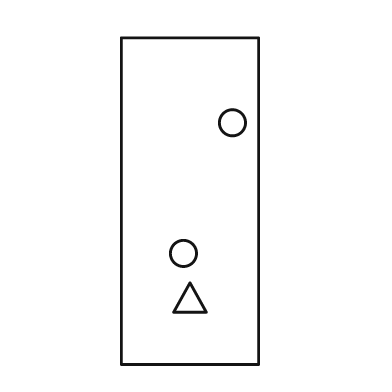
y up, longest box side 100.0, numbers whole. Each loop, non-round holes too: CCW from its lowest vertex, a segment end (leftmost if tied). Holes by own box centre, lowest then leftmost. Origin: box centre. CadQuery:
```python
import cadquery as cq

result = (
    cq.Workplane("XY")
    .moveTo(-21.0, -50.0)
    .lineTo(21.0, -50.0)
    .lineTo(21.0, 50.0)
    .lineTo(-21.0, 50.0)
    .close()
    .moveTo(-5.0, -34.0)
    .lineTo(5.0, -34.0)
    .lineTo(0.0, -25.0)
    .close()
    .moveTo(-2.0, -16.0)
    .circle(4.0)
    .moveTo(13.0, 24.0)
    .circle(4.0)
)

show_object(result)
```